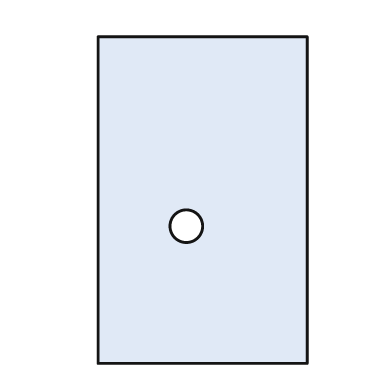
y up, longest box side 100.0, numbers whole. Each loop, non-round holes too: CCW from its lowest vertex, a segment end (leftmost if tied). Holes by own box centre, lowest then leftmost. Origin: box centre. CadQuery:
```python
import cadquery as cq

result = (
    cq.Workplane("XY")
    .moveTo(-32.0, -50.0)
    .lineTo(32.0, -50.0)
    .lineTo(32.0, 50.0)
    .lineTo(-32.0, 50.0)
    .close()
    .moveTo(-5.0, -8.0)
    .circle(5.0)
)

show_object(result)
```